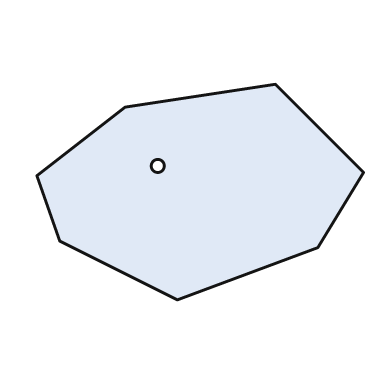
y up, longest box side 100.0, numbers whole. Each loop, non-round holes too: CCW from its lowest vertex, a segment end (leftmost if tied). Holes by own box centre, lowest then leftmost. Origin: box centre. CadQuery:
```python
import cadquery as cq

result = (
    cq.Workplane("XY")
    .moveTo(-7.0, -33.0)
    .lineTo(36.0, -17.0)
    .lineTo(50.0, 6.0)
    .lineTo(23.0, 33.0)
    .lineTo(-23.0, 26.0)
    .lineTo(-50.0, 5.0)
    .lineTo(-43.0, -15.0)
    .close()
    .moveTo(-13.0, 8.0)
    .circle(2.0)
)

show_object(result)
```